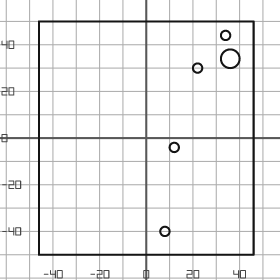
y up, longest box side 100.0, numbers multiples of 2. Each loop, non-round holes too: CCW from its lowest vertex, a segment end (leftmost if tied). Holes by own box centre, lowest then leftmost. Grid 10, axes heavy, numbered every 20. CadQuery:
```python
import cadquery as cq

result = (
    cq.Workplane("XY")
    .moveTo(-46.0, -50.0)
    .lineTo(46.0, -50.0)
    .lineTo(46.0, 50.0)
    .lineTo(-46.0, 50.0)
    .close()
    .moveTo(8.0, -40.0)
    .circle(2.0)
    .moveTo(12.0, -4.0)
    .circle(2.0)
    .moveTo(22.0, 30.0)
    .circle(2.0)
    .moveTo(36.0, 34.0)
    .circle(4.0)
    .moveTo(34.0, 44.0)
    .circle(2.0)
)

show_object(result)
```